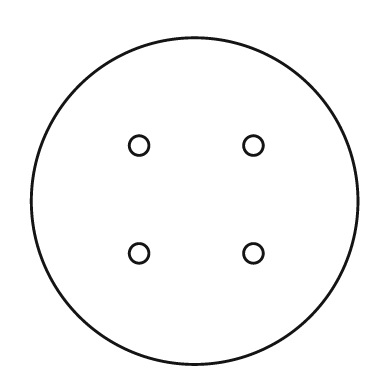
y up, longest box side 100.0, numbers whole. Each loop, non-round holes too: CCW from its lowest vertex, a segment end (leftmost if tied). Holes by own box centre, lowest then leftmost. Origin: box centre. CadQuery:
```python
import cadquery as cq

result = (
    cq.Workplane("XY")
    .moveTo(0.0, 0.0)
    .circle(50.0)
    .moveTo(-17.0, -16.0)
    .circle(3.0)
    .moveTo(18.0, -16.0)
    .circle(3.0)
    .moveTo(-17.0, 17.0)
    .circle(3.0)
    .moveTo(18.0, 17.0)
    .circle(3.0)
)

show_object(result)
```